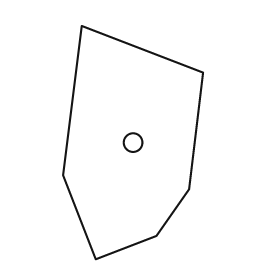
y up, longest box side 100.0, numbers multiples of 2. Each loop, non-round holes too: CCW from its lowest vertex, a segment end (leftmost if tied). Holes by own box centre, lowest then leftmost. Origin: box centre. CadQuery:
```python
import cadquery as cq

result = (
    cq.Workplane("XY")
    .moveTo(-16.0, -50.0)
    .lineTo(10.0, -40.0)
    .lineTo(24.0, -20.0)
    .lineTo(30.0, 30.0)
    .lineTo(-22.0, 50.0)
    .lineTo(-30.0, -14.0)
    .close()
    .moveTo(0.0, 0.0)
    .circle(4.0)
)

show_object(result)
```